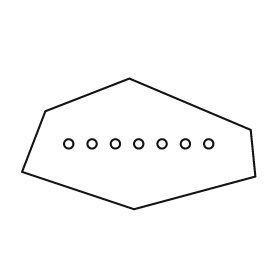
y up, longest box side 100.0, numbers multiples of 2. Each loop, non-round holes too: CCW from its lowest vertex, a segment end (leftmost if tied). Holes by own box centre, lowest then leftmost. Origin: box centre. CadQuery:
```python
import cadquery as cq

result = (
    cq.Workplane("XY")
    .moveTo(-2.0, -28.0)
    .lineTo(50.0, -14.0)
    .lineTo(48.0, 6.0)
    .lineTo(-4.0, 28.0)
    .lineTo(-40.0, 14.0)
    .lineTo(-50.0, -12.0)
    .close()
    .moveTo(-30.0, 0.0)
    .circle(2.0)
    .moveTo(-20.0, 0.0)
    .circle(2.0)
    .moveTo(-10.0, 0.0)
    .circle(2.0)
    .moveTo(0.0, 0.0)
    .circle(2.0)
    .moveTo(10.0, 0.0)
    .circle(2.0)
    .moveTo(20.0, 0.0)
    .circle(2.0)
    .moveTo(30.0, 0.0)
    .circle(2.0)
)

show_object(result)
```